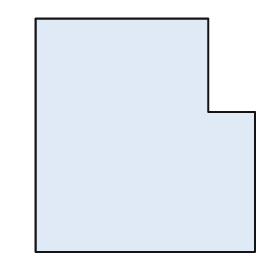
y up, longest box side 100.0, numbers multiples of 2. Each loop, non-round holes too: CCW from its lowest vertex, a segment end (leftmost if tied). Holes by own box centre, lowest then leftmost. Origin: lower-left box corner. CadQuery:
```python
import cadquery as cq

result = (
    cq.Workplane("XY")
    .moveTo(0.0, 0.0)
    .lineTo(94.0, 0.0)
    .lineTo(94.0, 60.0)
    .lineTo(74.0, 60.0)
    .lineTo(74.0, 100.0)
    .lineTo(0.0, 100.0)
    .close()
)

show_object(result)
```